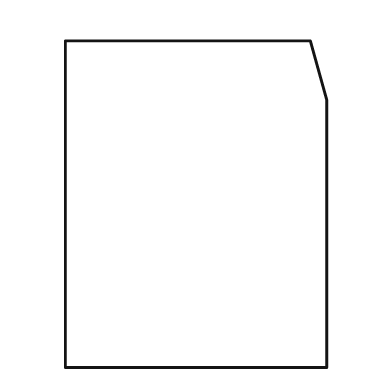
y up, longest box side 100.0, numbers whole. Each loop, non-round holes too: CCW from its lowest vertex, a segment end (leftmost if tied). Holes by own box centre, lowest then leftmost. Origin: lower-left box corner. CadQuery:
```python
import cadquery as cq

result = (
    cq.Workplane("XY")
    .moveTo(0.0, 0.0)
    .lineTo(80.0, 0.0)
    .lineTo(80.0, 82.0)
    .lineTo(75.0, 100.0)
    .lineTo(0.0, 100.0)
    .close()
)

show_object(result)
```